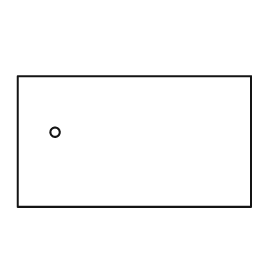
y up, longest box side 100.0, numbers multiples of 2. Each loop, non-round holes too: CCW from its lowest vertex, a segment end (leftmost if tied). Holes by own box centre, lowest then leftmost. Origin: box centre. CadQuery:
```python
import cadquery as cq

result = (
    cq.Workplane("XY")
    .moveTo(-50.0, -28.0)
    .lineTo(50.0, -28.0)
    .lineTo(50.0, 28.0)
    .lineTo(-50.0, 28.0)
    .close()
    .moveTo(-34.0, 4.0)
    .circle(2.0)
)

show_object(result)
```